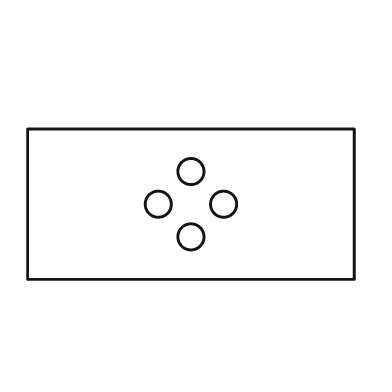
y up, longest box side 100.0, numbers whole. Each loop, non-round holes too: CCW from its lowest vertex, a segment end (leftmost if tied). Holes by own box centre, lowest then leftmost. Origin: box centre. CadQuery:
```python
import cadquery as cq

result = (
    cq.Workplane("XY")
    .moveTo(-50.0, -23.0)
    .lineTo(50.0, -23.0)
    .lineTo(50.0, 23.0)
    .lineTo(-50.0, 23.0)
    .close()
    .moveTo(0.0, -10.0)
    .circle(4.0)
    .moveTo(-10.0, 0.0)
    .circle(4.0)
    .moveTo(10.0, 0.0)
    .circle(4.0)
    .moveTo(0.0, 10.0)
    .circle(4.0)
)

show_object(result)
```